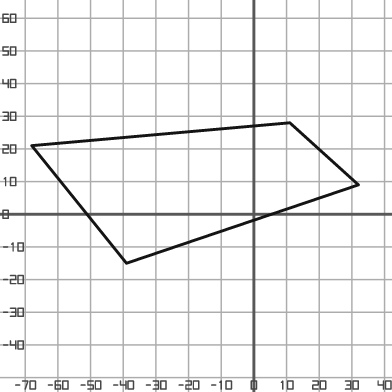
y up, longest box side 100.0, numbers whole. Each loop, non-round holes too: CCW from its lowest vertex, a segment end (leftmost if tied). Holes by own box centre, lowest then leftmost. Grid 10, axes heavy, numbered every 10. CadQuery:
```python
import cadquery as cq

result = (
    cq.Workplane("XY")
    .moveTo(-39.0, -15.0)
    .lineTo(32.0, 9.0)
    .lineTo(11.0, 28.0)
    .lineTo(-68.0, 21.0)
    .close()
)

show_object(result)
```